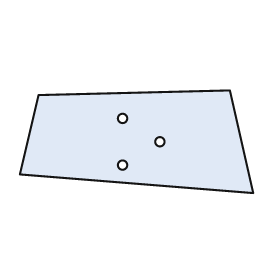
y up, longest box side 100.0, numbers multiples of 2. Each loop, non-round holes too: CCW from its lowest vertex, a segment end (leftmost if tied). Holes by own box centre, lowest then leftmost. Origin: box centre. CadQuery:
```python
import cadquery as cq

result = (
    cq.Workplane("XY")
    .moveTo(50.0, -22.0)
    .lineTo(40.0, 22.0)
    .lineTo(-42.0, 20.0)
    .lineTo(-50.0, -14.0)
    .close()
    .moveTo(-6.0, -10.0)
    .circle(2.0)
    .moveTo(10.0, 0.0)
    .circle(2.0)
    .moveTo(-6.0, 10.0)
    .circle(2.0)
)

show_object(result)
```